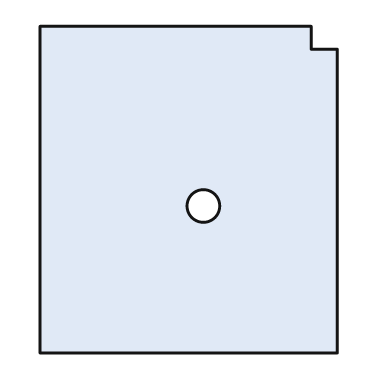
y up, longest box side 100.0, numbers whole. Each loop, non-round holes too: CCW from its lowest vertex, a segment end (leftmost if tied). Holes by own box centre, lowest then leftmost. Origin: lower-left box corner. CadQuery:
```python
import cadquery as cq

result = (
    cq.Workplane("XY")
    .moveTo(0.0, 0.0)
    .lineTo(91.0, 0.0)
    .lineTo(91.0, 93.0)
    .lineTo(83.0, 93.0)
    .lineTo(83.0, 100.0)
    .lineTo(0.0, 100.0)
    .close()
    .moveTo(50.0, 45.0)
    .circle(5.0)
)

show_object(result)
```